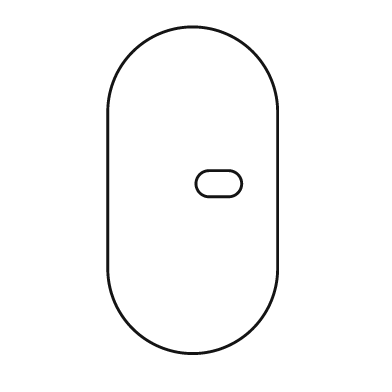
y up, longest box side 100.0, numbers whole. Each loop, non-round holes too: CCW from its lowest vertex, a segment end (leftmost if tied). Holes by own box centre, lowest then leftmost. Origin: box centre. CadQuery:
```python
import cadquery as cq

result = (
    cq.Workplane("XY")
    .moveTo(-26.0, -24.0)
    .threePointArc((0.0, -50.0), (26.0, -24.0))
    .lineTo(26.0, 24.0)
    .threePointArc((0.0, 50.0), (-26.0, 24.0))
    .close()
    .moveTo(5.0, -2.0)
    .lineTo(11.0, -2.0)
    .threePointArc((15.0, 2.0), (11.0, 6.0))
    .lineTo(5.0, 6.0)
    .threePointArc((1.0, 2.0), (5.0, -2.0))
    .close()
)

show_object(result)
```